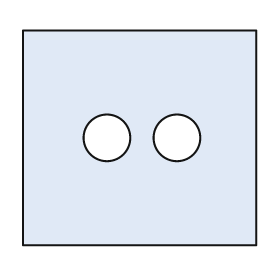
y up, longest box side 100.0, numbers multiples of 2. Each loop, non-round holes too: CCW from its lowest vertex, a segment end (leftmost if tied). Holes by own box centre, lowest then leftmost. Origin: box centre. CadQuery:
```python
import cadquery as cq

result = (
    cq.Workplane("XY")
    .moveTo(-50.0, -46.0)
    .lineTo(50.0, -46.0)
    .lineTo(50.0, 46.0)
    .lineTo(-50.0, 46.0)
    .close()
    .moveTo(-14.0, 0.0)
    .circle(10.0)
    .moveTo(16.0, 0.0)
    .circle(10.0)
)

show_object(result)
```